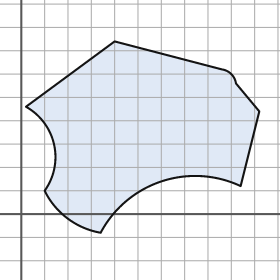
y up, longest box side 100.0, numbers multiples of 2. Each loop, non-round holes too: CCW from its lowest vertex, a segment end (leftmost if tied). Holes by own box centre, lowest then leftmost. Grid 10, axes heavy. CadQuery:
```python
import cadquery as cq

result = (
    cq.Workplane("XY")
    .moveTo(34.0, -8.0)
    .threePointArc((60.0, 14.0), (94.0, 12.0))
    .lineTo(102.0, 44.0)
    .lineTo(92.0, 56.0)
    .threePointArc((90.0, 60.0), (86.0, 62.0))
    .lineTo(40.0, 74.0)
    .lineTo(2.0, 46.0)
    .threePointArc((14.0, 30.0), (10.0, 10.0))
    .threePointArc((20.0, -2.0), (34.0, -8.0))
    .close()
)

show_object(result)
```